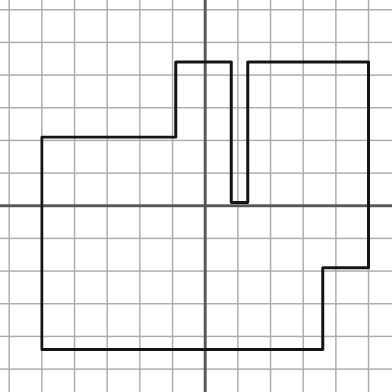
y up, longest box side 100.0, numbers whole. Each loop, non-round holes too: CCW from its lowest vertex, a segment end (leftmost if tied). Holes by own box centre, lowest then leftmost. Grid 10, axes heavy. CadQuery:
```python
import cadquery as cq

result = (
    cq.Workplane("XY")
    .moveTo(-50.0, -44.0)
    .lineTo(36.0, -44.0)
    .lineTo(36.0, -19.0)
    .lineTo(50.0, -19.0)
    .lineTo(50.0, 44.0)
    .lineTo(13.0, 44.0)
    .lineTo(13.0, 1.0)
    .lineTo(8.0, 1.0)
    .lineTo(8.0, 44.0)
    .lineTo(-9.0, 44.0)
    .lineTo(-9.0, 21.0)
    .lineTo(-50.0, 21.0)
    .close()
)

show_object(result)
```